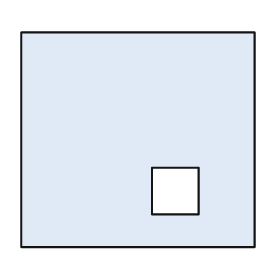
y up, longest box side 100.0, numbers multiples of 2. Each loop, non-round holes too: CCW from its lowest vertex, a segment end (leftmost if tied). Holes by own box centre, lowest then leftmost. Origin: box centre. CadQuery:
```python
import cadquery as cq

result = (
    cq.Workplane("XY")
    .moveTo(-50.0, -46.0)
    .lineTo(50.0, -46.0)
    .lineTo(50.0, 46.0)
    .lineTo(-50.0, 46.0)
    .close()
    .moveTo(6.0, -32.0)
    .lineTo(26.0, -32.0)
    .lineTo(26.0, -12.0)
    .lineTo(6.0, -12.0)
    .close()
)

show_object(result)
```